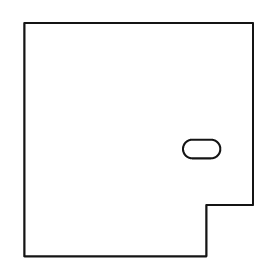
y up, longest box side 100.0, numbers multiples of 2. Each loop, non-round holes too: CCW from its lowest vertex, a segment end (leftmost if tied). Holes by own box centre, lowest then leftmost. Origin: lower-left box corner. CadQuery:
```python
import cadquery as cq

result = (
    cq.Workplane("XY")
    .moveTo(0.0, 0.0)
    .lineTo(78.0, 0.0)
    .lineTo(78.0, 22.0)
    .lineTo(98.0, 22.0)
    .lineTo(98.0, 100.0)
    .lineTo(0.0, 100.0)
    .close()
    .moveTo(72.0, 42.0)
    .lineTo(80.0, 42.0)
    .threePointArc((84.0, 46.0), (80.0, 50.0))
    .lineTo(72.0, 50.0)
    .threePointArc((68.0, 46.0), (72.0, 42.0))
    .close()
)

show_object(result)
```